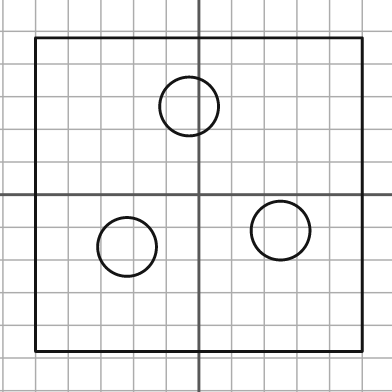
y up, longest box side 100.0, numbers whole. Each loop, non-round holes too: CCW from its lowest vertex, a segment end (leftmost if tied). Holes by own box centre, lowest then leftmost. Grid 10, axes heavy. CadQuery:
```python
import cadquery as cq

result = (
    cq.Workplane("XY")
    .moveTo(-50.0, -48.0)
    .lineTo(50.0, -48.0)
    .lineTo(50.0, 48.0)
    .lineTo(-50.0, 48.0)
    .close()
    .moveTo(-22.0, -16.0)
    .circle(9.0)
    .moveTo(25.0, -11.0)
    .circle(9.0)
    .moveTo(-3.0, 27.0)
    .circle(9.0)
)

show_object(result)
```